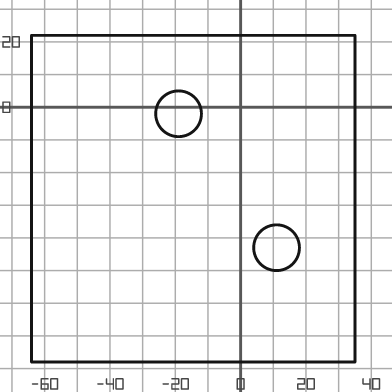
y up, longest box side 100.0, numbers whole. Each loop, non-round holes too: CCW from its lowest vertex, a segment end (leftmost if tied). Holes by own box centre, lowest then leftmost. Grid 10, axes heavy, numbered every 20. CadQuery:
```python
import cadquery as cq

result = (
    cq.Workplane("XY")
    .moveTo(-64.0, -78.0)
    .lineTo(35.0, -78.0)
    .lineTo(35.0, 22.0)
    .lineTo(-64.0, 22.0)
    .close()
    .moveTo(11.0, -43.0)
    .circle(7.0)
    .moveTo(-19.0, -2.0)
    .circle(7.0)
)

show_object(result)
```